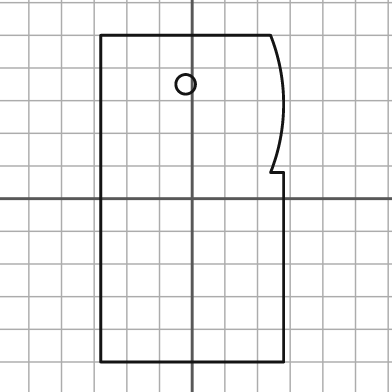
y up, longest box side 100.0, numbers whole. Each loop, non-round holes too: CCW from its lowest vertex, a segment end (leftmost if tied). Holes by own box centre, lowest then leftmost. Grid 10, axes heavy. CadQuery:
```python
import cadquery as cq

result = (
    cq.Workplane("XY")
    .moveTo(-28.0, -50.0)
    .lineTo(28.0, -50.0)
    .lineTo(28.0, 8.0)
    .lineTo(24.0, 8.0)
    .threePointArc((28.0, 29.0), (24.0, 50.0))
    .lineTo(-28.0, 50.0)
    .close()
    .moveTo(-2.0, 35.0)
    .circle(3.0)
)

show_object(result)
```